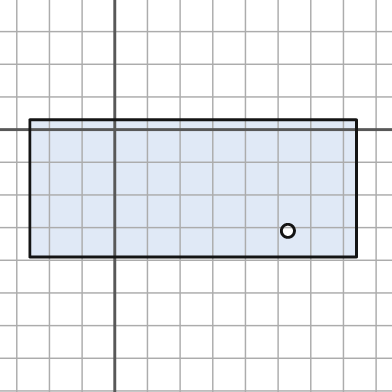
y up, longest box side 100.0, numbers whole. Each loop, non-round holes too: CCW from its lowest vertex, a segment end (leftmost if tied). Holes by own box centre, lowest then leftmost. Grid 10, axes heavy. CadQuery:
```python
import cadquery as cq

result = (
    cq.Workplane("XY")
    .moveTo(-26.0, -39.0)
    .lineTo(74.0, -39.0)
    .lineTo(74.0, 3.0)
    .lineTo(-26.0, 3.0)
    .close()
    .moveTo(53.0, -31.0)
    .circle(2.0)
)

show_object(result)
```